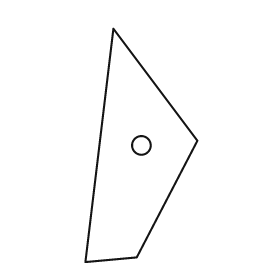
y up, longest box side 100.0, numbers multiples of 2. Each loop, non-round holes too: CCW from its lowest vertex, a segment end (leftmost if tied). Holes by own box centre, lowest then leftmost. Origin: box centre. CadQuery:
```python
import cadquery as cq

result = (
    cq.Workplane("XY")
    .moveTo(-24.0, -50.0)
    .lineTo(-2.0, -48.0)
    .lineTo(24.0, 2.0)
    .lineTo(-12.0, 50.0)
    .close()
    .moveTo(0.0, 0.0)
    .circle(4.0)
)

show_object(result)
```